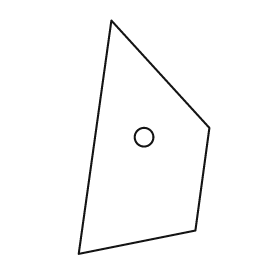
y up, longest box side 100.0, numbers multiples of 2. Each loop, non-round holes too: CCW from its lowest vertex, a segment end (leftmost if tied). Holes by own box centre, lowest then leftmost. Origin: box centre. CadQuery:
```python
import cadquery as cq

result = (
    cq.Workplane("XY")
    .moveTo(-28.0, -50.0)
    .lineTo(22.0, -40.0)
    .lineTo(28.0, 4.0)
    .lineTo(-14.0, 50.0)
    .close()
    .moveTo(0.0, 0.0)
    .circle(4.0)
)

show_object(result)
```